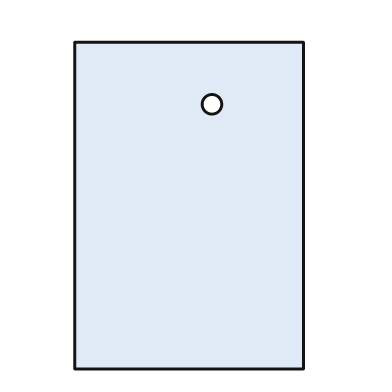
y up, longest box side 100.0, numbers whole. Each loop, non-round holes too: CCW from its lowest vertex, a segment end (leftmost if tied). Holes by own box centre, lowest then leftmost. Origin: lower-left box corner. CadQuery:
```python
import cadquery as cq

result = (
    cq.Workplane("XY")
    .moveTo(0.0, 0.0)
    .lineTo(70.0, 0.0)
    .lineTo(70.0, 100.0)
    .lineTo(0.0, 100.0)
    .close()
    .moveTo(42.0, 81.0)
    .circle(3.0)
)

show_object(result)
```